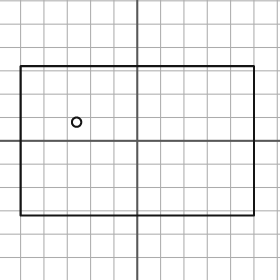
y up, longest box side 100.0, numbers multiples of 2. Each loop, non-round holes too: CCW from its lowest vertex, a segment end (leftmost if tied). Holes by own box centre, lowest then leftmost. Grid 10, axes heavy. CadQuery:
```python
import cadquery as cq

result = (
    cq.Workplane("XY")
    .moveTo(-50.0, -32.0)
    .lineTo(50.0, -32.0)
    .lineTo(50.0, 32.0)
    .lineTo(-50.0, 32.0)
    .close()
    .moveTo(-26.0, 8.0)
    .circle(2.0)
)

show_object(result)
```